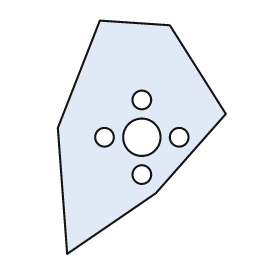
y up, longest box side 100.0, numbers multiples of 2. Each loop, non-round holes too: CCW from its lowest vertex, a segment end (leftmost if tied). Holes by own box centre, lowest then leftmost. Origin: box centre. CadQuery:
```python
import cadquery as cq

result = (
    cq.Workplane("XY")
    .moveTo(-32.0, -50.0)
    .lineTo(6.0, -24.0)
    .lineTo(36.0, 10.0)
    .lineTo(12.0, 48.0)
    .lineTo(-18.0, 50.0)
    .lineTo(-36.0, 4.0)
    .close()
    .moveTo(0.0, -16.0)
    .circle(4.0)
    .moveTo(-16.0, 0.0)
    .circle(4.0)
    .moveTo(0.0, 0.0)
    .circle(8.0)
    .moveTo(16.0, 0.0)
    .circle(4.0)
    .moveTo(0.0, 16.0)
    .circle(4.0)
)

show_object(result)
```